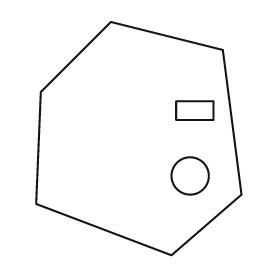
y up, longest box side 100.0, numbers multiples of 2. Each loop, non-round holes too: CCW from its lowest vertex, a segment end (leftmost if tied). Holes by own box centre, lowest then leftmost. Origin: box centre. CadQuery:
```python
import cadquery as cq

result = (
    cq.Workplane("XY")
    .moveTo(14.0, -50.0)
    .lineTo(44.0, -24.0)
    .lineTo(36.0, 38.0)
    .lineTo(-12.0, 50.0)
    .lineTo(-42.0, 20.0)
    .lineTo(-44.0, -28.0)
    .close()
    .moveTo(22.0, -16.0)
    .circle(8.0)
    .moveTo(16.0, 8.0)
    .lineTo(32.0, 8.0)
    .lineTo(32.0, 16.0)
    .lineTo(16.0, 16.0)
    .close()
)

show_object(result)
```